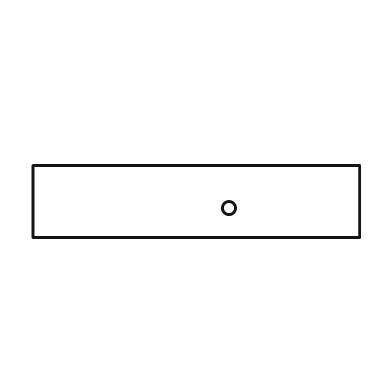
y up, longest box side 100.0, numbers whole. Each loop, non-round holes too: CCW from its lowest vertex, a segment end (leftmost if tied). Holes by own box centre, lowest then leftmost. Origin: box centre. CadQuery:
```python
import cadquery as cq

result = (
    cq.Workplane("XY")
    .moveTo(-50.0, -11.0)
    .lineTo(50.0, -11.0)
    .lineTo(50.0, 11.0)
    .lineTo(-50.0, 11.0)
    .close()
    .moveTo(10.0, -2.0)
    .circle(2.0)
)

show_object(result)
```